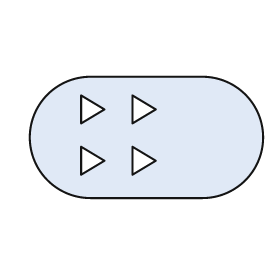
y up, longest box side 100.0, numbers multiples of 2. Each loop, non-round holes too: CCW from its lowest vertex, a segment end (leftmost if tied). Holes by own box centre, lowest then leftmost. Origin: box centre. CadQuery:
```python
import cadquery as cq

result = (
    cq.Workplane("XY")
    .moveTo(-24.0, -26.0)
    .lineTo(24.0, -26.0)
    .threePointArc((50.0, 0.0), (24.0, 26.0))
    .lineTo(-24.0, 26.0)
    .threePointArc((-50.0, 0.0), (-24.0, -26.0))
    .close()
    .moveTo(-28.0, -16.0)
    .lineTo(-18.0, -10.0)
    .lineTo(-28.0, -4.0)
    .close()
    .moveTo(-6.0, -16.0)
    .lineTo(4.0, -10.0)
    .lineTo(-6.0, -4.0)
    .close()
    .moveTo(-28.0, 6.0)
    .lineTo(-18.0, 12.0)
    .lineTo(-28.0, 18.0)
    .close()
    .moveTo(-6.0, 6.0)
    .lineTo(4.0, 12.0)
    .lineTo(-6.0, 18.0)
    .close()
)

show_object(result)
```